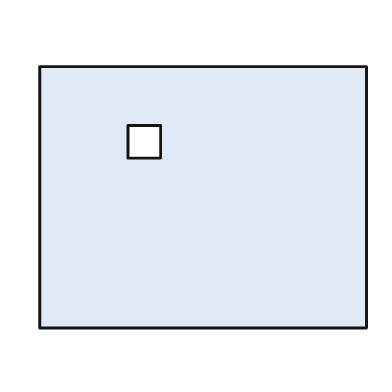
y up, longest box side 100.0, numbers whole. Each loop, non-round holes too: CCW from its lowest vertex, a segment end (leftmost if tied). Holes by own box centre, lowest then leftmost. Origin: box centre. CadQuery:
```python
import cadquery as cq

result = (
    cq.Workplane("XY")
    .moveTo(-50.0, -40.0)
    .lineTo(50.0, -40.0)
    .lineTo(50.0, 40.0)
    .lineTo(-50.0, 40.0)
    .close()
    .moveTo(-23.0, 12.0)
    .lineTo(-13.0, 12.0)
    .lineTo(-13.0, 22.0)
    .lineTo(-23.0, 22.0)
    .close()
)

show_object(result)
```